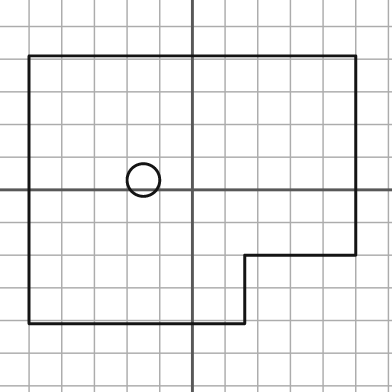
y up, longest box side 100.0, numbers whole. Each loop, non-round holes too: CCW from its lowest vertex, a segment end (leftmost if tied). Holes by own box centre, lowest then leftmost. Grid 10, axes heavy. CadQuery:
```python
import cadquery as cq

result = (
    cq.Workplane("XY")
    .moveTo(-50.0, -41.0)
    .lineTo(16.0, -41.0)
    .lineTo(16.0, -20.0)
    .lineTo(50.0, -20.0)
    .lineTo(50.0, 41.0)
    .lineTo(-50.0, 41.0)
    .close()
    .moveTo(-15.0, 3.0)
    .circle(5.0)
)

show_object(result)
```